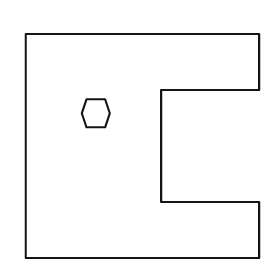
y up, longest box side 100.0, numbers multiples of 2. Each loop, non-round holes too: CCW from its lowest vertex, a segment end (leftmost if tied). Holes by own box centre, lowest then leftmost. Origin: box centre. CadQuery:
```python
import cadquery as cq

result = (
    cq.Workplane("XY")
    .moveTo(-50.0, -48.0)
    .lineTo(50.0, -48.0)
    .lineTo(50.0, -24.0)
    .lineTo(8.0, -24.0)
    .lineTo(8.0, 24.0)
    .lineTo(50.0, 24.0)
    .lineTo(50.0, 48.0)
    .lineTo(-50.0, 48.0)
    .close()
    .moveTo(-24.0, 8.0)
    .lineTo(-16.0, 8.0)
    .lineTo(-14.0, 14.0)
    .lineTo(-16.0, 20.0)
    .lineTo(-24.0, 20.0)
    .lineTo(-26.0, 14.0)
    .close()
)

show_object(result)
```